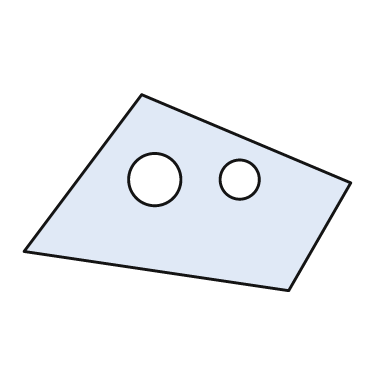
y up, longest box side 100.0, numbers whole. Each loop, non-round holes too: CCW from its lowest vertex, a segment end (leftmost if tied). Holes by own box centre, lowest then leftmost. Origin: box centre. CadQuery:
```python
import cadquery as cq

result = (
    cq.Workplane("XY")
    .moveTo(31.0, -30.0)
    .lineTo(50.0, 3.0)
    .lineTo(-14.0, 30.0)
    .lineTo(-50.0, -18.0)
    .close()
    .moveTo(-10.0, 4.0)
    .circle(8.0)
    .moveTo(16.0, 4.0)
    .circle(6.0)
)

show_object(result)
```